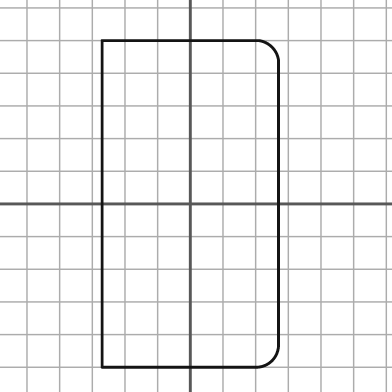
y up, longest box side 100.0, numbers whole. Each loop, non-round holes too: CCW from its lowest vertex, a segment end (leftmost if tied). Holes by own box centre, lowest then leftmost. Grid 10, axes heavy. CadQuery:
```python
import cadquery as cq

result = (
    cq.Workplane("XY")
    .moveTo(-27.0, -50.0)
    .lineTo(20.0, -50.0)
    .threePointArc((25.0, -48.0), (27.0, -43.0))
    .lineTo(27.0, 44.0)
    .threePointArc((25.0, 48.0), (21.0, 50.0))
    .lineTo(-27.0, 50.0)
    .close()
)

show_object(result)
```